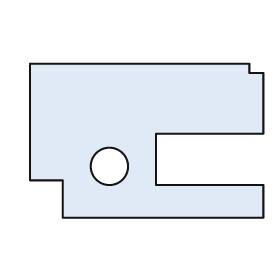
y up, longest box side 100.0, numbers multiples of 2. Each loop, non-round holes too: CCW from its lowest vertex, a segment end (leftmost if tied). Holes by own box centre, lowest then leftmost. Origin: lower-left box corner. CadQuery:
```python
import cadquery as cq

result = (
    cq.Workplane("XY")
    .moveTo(14.0, 0.0)
    .lineTo(100.0, 0.0)
    .lineTo(100.0, 14.0)
    .lineTo(54.0, 14.0)
    .lineTo(54.0, 36.0)
    .lineTo(100.0, 36.0)
    .lineTo(100.0, 62.0)
    .lineTo(94.0, 62.0)
    .lineTo(94.0, 66.0)
    .lineTo(0.0, 66.0)
    .lineTo(0.0, 16.0)
    .lineTo(14.0, 16.0)
    .close()
    .moveTo(34.0, 22.0)
    .circle(8.0)
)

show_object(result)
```